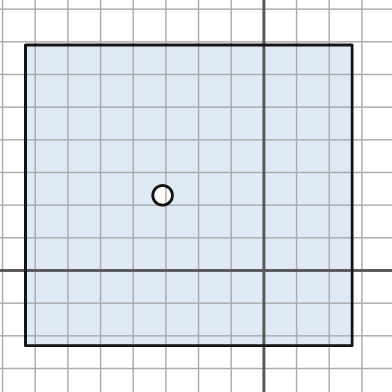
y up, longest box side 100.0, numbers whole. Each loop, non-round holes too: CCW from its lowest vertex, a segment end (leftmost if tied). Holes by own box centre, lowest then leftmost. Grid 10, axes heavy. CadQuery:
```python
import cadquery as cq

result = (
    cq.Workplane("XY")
    .moveTo(-73.0, -23.0)
    .lineTo(27.0, -23.0)
    .lineTo(27.0, 69.0)
    .lineTo(-73.0, 69.0)
    .close()
    .moveTo(-31.0, 23.0)
    .circle(3.0)
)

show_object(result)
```